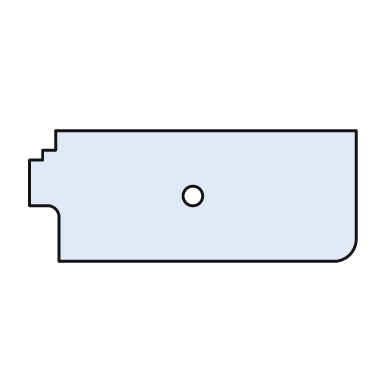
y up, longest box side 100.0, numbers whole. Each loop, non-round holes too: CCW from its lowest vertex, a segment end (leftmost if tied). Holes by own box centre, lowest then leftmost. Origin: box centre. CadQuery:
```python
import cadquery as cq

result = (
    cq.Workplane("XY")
    .moveTo(-41.0, -20.0)
    .lineTo(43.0, -20.0)
    .threePointArc((48.0, -18.0), (50.0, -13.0))
    .lineTo(50.0, 20.0)
    .lineTo(-42.0, 20.0)
    .lineTo(-42.0, 14.0)
    .lineTo(-46.0, 14.0)
    .lineTo(-46.0, 11.0)
    .lineTo(-50.0, 11.0)
    .lineTo(-50.0, -3.0)
    .lineTo(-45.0, -3.0)
    .threePointArc((-42.0, -4.0), (-41.0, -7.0))
    .close()
    .moveTo(0.0, 0.0)
    .circle(3.0)
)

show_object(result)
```